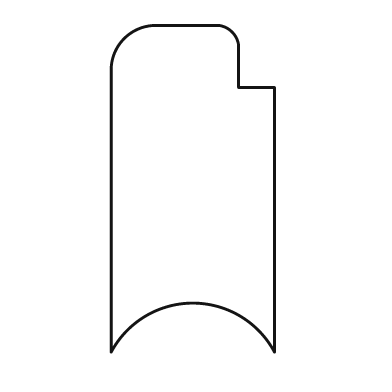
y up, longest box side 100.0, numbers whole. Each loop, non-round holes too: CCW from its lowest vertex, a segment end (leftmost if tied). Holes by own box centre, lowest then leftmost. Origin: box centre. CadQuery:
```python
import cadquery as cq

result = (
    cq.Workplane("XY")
    .moveTo(-25.0, -50.0)
    .threePointArc((0.0, -35.0), (25.0, -50.0))
    .lineTo(25.0, 31.0)
    .lineTo(14.0, 31.0)
    .lineTo(14.0, 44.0)
    .threePointArc((12.0, 48.0), (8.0, 50.0))
    .lineTo(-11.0, 50.0)
    .threePointArc((-21.0, 46.0), (-25.0, 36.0))
    .close()
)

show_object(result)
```